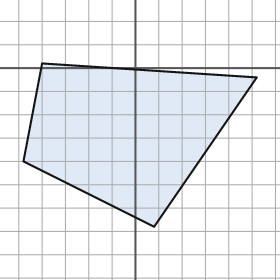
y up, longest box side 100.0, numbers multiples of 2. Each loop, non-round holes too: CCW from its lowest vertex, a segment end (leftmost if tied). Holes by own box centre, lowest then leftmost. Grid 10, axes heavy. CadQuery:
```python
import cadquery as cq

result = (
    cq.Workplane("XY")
    .moveTo(8.0, -68.0)
    .lineTo(52.0, -4.0)
    .lineTo(-40.0, 2.0)
    .lineTo(-48.0, -40.0)
    .close()
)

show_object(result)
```